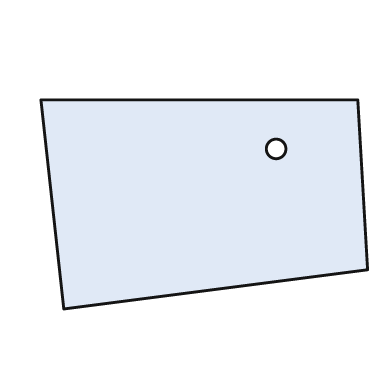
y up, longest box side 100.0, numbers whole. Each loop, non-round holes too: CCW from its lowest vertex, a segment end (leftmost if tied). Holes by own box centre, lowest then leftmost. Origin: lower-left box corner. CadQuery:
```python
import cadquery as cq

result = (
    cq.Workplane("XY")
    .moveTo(7.0, 0.0)
    .lineTo(100.0, 12.0)
    .lineTo(97.0, 64.0)
    .lineTo(0.0, 64.0)
    .close()
    .moveTo(72.0, 49.0)
    .circle(3.0)
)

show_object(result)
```